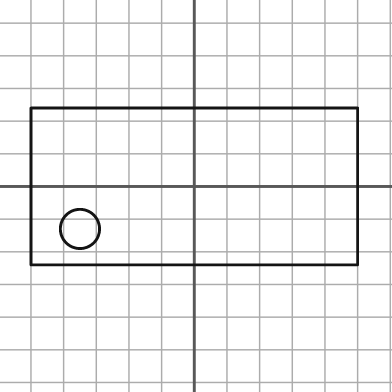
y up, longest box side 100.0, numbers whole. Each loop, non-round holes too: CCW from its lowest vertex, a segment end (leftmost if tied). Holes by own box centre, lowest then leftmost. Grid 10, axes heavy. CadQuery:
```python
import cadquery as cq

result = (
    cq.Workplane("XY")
    .moveTo(-50.0, -24.0)
    .lineTo(50.0, -24.0)
    .lineTo(50.0, 24.0)
    .lineTo(-50.0, 24.0)
    .close()
    .moveTo(-35.0, -13.0)
    .circle(6.0)
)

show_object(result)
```